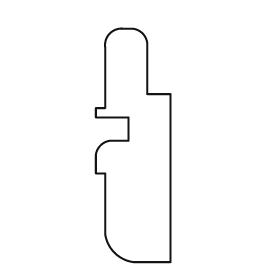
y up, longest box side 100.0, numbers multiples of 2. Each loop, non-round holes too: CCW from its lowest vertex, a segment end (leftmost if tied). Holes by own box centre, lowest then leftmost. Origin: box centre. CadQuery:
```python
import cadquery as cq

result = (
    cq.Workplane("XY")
    .moveTo(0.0, -50.0)
    .lineTo(16.0, -50.0)
    .lineTo(16.0, 22.0)
    .lineTo(6.0, 22.0)
    .lineTo(6.0, 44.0)
    .threePointArc((4.0, 48.0), (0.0, 50.0))
    .lineTo(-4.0, 50.0)
    .threePointArc((-10.0, 48.0), (-12.0, 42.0))
    .lineTo(-12.0, 16.0)
    .lineTo(-16.0, 16.0)
    .lineTo(-16.0, 12.0)
    .lineTo(-2.0, 12.0)
    .lineTo(-2.0, 2.0)
    .lineTo(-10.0, 2.0)
    .threePointArc((-14.0, 0.0), (-16.0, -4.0))
    .lineTo(-16.0, -12.0)
    .lineTo(-12.0, -12.0)
    .lineTo(-12.0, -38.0)
    .threePointArc((-8.0, -46.0), (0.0, -50.0))
    .close()
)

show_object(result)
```